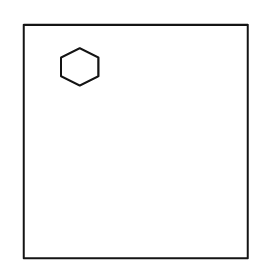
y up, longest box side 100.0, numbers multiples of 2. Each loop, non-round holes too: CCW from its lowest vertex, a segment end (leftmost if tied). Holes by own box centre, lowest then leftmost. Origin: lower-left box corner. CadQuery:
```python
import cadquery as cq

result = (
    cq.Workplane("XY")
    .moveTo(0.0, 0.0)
    .lineTo(96.0, 0.0)
    .lineTo(96.0, 100.0)
    .lineTo(0.0, 100.0)
    .close()
    .moveTo(24.0, 74.0)
    .lineTo(32.0, 78.0)
    .lineTo(32.0, 86.0)
    .lineTo(24.0, 90.0)
    .lineTo(16.0, 86.0)
    .lineTo(16.0, 78.0)
    .close()
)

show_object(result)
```